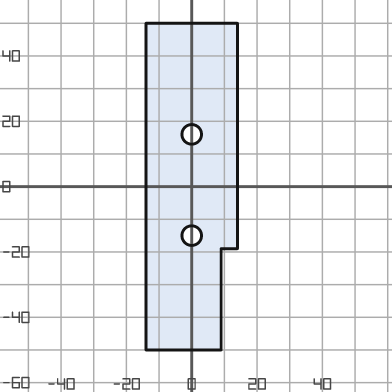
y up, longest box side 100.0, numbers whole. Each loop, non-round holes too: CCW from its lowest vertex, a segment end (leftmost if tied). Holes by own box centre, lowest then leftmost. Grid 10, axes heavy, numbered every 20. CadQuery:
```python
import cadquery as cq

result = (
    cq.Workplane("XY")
    .moveTo(-14.0, -50.0)
    .lineTo(9.0, -50.0)
    .lineTo(9.0, -19.0)
    .lineTo(14.0, -19.0)
    .lineTo(14.0, 50.0)
    .lineTo(-14.0, 50.0)
    .close()
    .moveTo(0.0, -15.0)
    .circle(3.0)
    .moveTo(0.0, 16.0)
    .circle(3.0)
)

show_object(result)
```